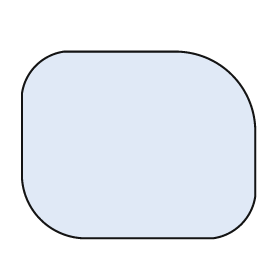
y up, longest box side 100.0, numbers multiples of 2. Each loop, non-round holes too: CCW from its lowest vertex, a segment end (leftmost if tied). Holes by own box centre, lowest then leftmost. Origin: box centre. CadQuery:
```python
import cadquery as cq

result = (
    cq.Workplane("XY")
    .moveTo(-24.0, -40.0)
    .lineTo(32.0, -40.0)
    .threePointArc((44.0, -34.0), (50.0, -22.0))
    .lineTo(50.0, 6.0)
    .threePointArc((40.0, 30.0), (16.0, 40.0))
    .lineTo(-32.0, 40.0)
    .threePointArc((-44.0, 34.0), (-50.0, 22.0))
    .lineTo(-50.0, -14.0)
    .threePointArc((-42.0, -32.0), (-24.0, -40.0))
    .close()
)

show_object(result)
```